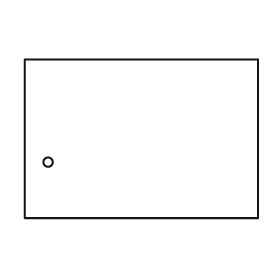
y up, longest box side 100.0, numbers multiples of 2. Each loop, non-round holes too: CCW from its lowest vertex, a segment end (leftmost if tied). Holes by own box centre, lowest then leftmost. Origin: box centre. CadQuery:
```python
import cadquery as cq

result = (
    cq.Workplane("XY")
    .moveTo(-50.0, -34.0)
    .lineTo(50.0, -34.0)
    .lineTo(50.0, 34.0)
    .lineTo(-50.0, 34.0)
    .close()
    .moveTo(-40.0, -10.0)
    .circle(2.0)
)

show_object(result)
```